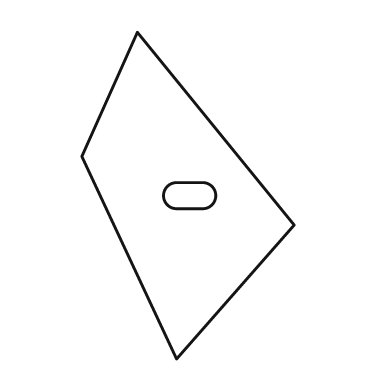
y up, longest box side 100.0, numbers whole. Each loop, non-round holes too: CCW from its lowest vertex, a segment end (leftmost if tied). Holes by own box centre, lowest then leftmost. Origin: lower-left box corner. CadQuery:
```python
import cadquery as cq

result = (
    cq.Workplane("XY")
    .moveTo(29.0, 0.0)
    .lineTo(65.0, 41.0)
    .lineTo(17.0, 100.0)
    .lineTo(0.0, 62.0)
    .close()
    .moveTo(29.0, 46.0)
    .lineTo(37.0, 46.0)
    .threePointArc((41.0, 50.0), (37.0, 54.0))
    .lineTo(29.0, 54.0)
    .threePointArc((25.0, 50.0), (29.0, 46.0))
    .close()
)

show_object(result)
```